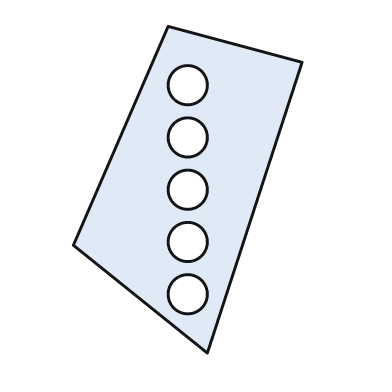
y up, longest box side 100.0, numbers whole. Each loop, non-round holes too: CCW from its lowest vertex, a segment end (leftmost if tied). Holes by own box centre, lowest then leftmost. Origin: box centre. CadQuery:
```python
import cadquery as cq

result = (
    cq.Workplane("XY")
    .moveTo(6.0, -50.0)
    .lineTo(35.0, 39.0)
    .lineTo(-6.0, 50.0)
    .lineTo(-35.0, -17.0)
    .close()
    .moveTo(0.0, -32.0)
    .circle(6.0)
    .moveTo(0.0, -16.0)
    .circle(6.0)
    .moveTo(0.0, 0.0)
    .circle(6.0)
    .moveTo(0.0, 16.0)
    .circle(6.0)
    .moveTo(0.0, 32.0)
    .circle(6.0)
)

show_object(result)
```